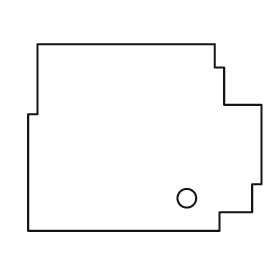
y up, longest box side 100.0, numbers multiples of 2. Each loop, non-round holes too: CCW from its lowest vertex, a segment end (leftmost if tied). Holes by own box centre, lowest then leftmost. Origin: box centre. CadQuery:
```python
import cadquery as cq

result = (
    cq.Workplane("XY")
    .moveTo(-50.0, -40.0)
    .lineTo(32.0, -40.0)
    .lineTo(32.0, -32.0)
    .lineTo(46.0, -32.0)
    .lineTo(46.0, -20.0)
    .lineTo(50.0, -20.0)
    .lineTo(50.0, 14.0)
    .lineTo(34.0, 14.0)
    .lineTo(34.0, 30.0)
    .lineTo(30.0, 30.0)
    .lineTo(30.0, 40.0)
    .lineTo(-46.0, 40.0)
    .lineTo(-46.0, 10.0)
    .lineTo(-50.0, 10.0)
    .close()
    .moveTo(18.0, -26.0)
    .circle(4.0)
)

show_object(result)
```